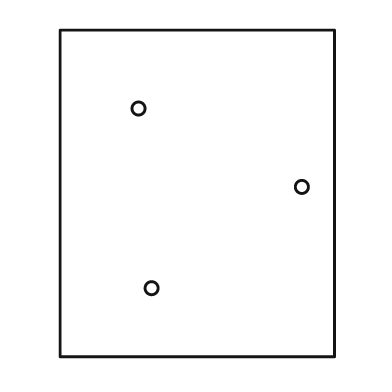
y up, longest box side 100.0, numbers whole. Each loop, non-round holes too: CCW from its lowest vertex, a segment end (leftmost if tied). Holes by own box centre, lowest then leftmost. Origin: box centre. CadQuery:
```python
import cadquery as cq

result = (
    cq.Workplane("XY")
    .moveTo(-42.0, -50.0)
    .lineTo(42.0, -50.0)
    .lineTo(42.0, 50.0)
    .lineTo(-42.0, 50.0)
    .close()
    .moveTo(-14.0, -29.0)
    .circle(2.0)
    .moveTo(32.0, 2.0)
    .circle(2.0)
    .moveTo(-18.0, 26.0)
    .circle(2.0)
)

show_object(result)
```